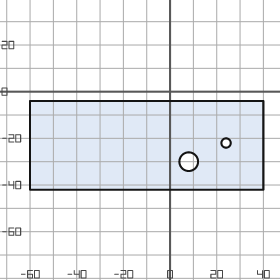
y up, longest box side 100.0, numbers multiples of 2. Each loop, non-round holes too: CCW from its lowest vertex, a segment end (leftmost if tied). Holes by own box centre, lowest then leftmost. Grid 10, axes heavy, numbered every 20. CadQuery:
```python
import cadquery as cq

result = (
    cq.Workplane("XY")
    .moveTo(-60.0, -42.0)
    .lineTo(40.0, -42.0)
    .lineTo(40.0, -4.0)
    .lineTo(-60.0, -4.0)
    .close()
    .moveTo(8.0, -30.0)
    .circle(4.0)
    .moveTo(24.0, -22.0)
    .circle(2.0)
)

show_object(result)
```